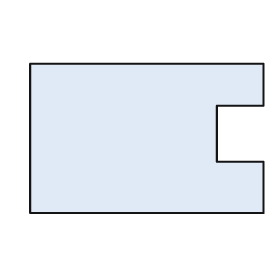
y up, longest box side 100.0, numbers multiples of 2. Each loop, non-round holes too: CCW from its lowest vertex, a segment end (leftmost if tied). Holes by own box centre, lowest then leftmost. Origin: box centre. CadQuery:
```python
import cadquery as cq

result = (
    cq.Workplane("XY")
    .moveTo(-50.0, -32.0)
    .lineTo(50.0, -32.0)
    .lineTo(50.0, -10.0)
    .lineTo(30.0, -10.0)
    .lineTo(30.0, 14.0)
    .lineTo(50.0, 14.0)
    .lineTo(50.0, 32.0)
    .lineTo(-50.0, 32.0)
    .close()
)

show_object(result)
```